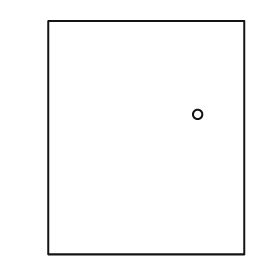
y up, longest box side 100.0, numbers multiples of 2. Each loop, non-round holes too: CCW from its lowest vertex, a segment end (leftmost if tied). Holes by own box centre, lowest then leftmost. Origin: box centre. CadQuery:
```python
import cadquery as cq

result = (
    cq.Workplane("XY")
    .moveTo(-42.0, -50.0)
    .lineTo(42.0, -50.0)
    .lineTo(42.0, 50.0)
    .lineTo(-42.0, 50.0)
    .close()
    .moveTo(22.0, 10.0)
    .circle(2.0)
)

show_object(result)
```